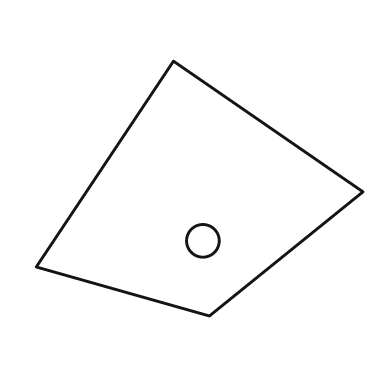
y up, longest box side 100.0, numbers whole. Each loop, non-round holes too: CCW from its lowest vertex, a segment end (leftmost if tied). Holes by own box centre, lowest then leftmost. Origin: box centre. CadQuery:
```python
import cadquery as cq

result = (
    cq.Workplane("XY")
    .moveTo(3.0, -39.0)
    .lineTo(50.0, -1.0)
    .lineTo(-8.0, 39.0)
    .lineTo(-50.0, -24.0)
    .close()
    .moveTo(1.0, -16.0)
    .circle(5.0)
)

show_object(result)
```